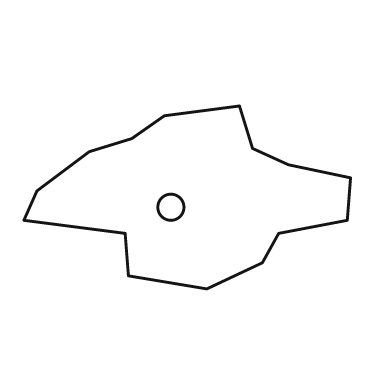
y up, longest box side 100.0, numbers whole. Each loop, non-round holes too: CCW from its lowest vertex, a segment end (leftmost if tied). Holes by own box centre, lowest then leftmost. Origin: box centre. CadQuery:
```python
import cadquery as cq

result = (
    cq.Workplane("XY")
    .moveTo(6.0, -28.0)
    .lineTo(23.0, -20.0)
    .lineTo(28.0, -11.0)
    .lineTo(49.0, -7.0)
    .lineTo(50.0, 6.0)
    .lineTo(31.0, 10.0)
    .lineTo(20.0, 15.0)
    .lineTo(16.0, 28.0)
    .lineTo(-7.0, 25.0)
    .lineTo(-17.0, 18.0)
    .lineTo(-30.0, 14.0)
    .lineTo(-46.0, 2.0)
    .lineTo(-50.0, -7.0)
    .lineTo(-19.0, -11.0)
    .lineTo(-18.0, -24.0)
    .close()
    .moveTo(-5.0, -3.0)
    .circle(4.0)
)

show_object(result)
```